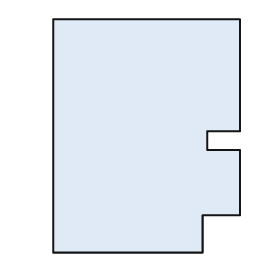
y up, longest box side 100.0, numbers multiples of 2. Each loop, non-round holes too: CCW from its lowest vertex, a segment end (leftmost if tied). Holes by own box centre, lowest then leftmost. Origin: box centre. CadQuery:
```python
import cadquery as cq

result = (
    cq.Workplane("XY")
    .moveTo(-40.0, -50.0)
    .lineTo(24.0, -50.0)
    .lineTo(24.0, -34.0)
    .lineTo(40.0, -34.0)
    .lineTo(40.0, -6.0)
    .lineTo(26.0, -6.0)
    .lineTo(26.0, 2.0)
    .lineTo(40.0, 2.0)
    .lineTo(40.0, 50.0)
    .lineTo(-40.0, 50.0)
    .close()
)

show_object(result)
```